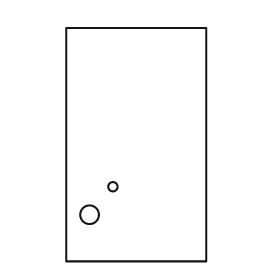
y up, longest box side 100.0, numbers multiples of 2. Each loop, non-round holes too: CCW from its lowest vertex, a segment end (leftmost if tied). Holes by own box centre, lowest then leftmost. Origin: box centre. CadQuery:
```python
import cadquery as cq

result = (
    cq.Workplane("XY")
    .moveTo(-30.0, -50.0)
    .lineTo(30.0, -50.0)
    .lineTo(30.0, 50.0)
    .lineTo(-30.0, 50.0)
    .close()
    .moveTo(-20.0, -30.0)
    .circle(4.0)
    .moveTo(-10.0, -18.0)
    .circle(2.0)
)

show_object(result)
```